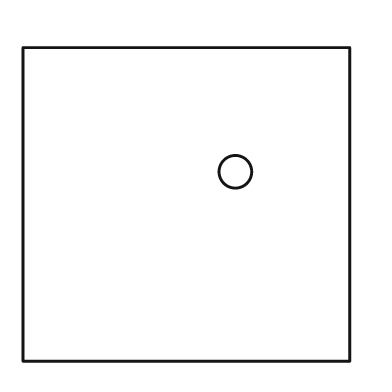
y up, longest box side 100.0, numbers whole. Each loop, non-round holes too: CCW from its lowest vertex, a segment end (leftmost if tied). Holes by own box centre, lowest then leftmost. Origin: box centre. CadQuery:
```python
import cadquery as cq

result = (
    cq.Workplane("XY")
    .moveTo(-50.0, -48.0)
    .lineTo(50.0, -48.0)
    .lineTo(50.0, 48.0)
    .lineTo(-50.0, 48.0)
    .close()
    .moveTo(15.0, 10.0)
    .circle(5.0)
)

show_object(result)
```